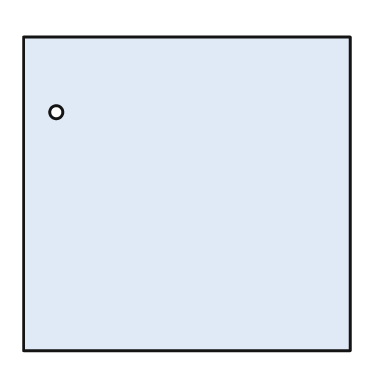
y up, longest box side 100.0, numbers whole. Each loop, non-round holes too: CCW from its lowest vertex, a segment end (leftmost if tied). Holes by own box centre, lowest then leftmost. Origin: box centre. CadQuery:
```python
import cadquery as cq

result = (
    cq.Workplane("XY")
    .moveTo(-50.0, -48.0)
    .lineTo(50.0, -48.0)
    .lineTo(50.0, 48.0)
    .lineTo(-50.0, 48.0)
    .close()
    .moveTo(-40.0, 25.0)
    .circle(2.0)
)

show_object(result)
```